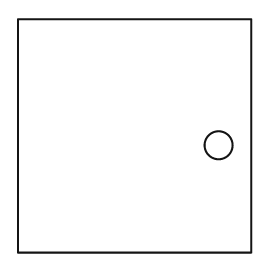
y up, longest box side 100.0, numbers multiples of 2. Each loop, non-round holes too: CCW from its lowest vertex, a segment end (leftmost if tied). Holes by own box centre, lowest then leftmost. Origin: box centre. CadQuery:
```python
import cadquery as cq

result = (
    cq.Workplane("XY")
    .moveTo(-50.0, -50.0)
    .lineTo(50.0, -50.0)
    .lineTo(50.0, 50.0)
    .lineTo(-50.0, 50.0)
    .close()
    .moveTo(36.0, -4.0)
    .circle(6.0)
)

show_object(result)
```